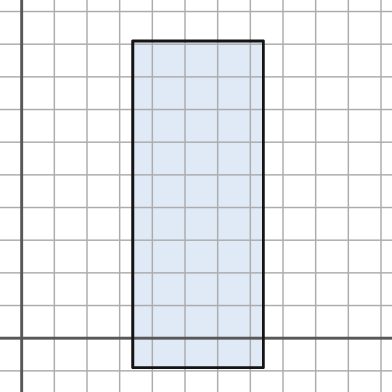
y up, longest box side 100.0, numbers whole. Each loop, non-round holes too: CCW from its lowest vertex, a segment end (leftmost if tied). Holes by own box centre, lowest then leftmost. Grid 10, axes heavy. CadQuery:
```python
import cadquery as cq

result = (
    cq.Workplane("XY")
    .moveTo(34.0, -9.0)
    .lineTo(74.0, -9.0)
    .lineTo(74.0, 91.0)
    .lineTo(34.0, 91.0)
    .close()
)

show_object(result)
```